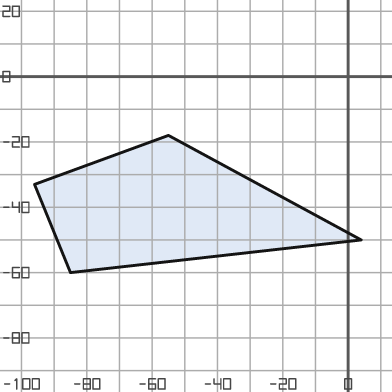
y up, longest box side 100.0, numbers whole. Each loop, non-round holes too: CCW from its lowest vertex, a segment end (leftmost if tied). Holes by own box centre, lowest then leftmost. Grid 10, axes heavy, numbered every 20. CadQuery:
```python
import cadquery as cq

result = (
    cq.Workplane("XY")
    .moveTo(-85.0, -60.0)
    .lineTo(4.0, -50.0)
    .lineTo(-55.0, -18.0)
    .lineTo(-96.0, -33.0)
    .close()
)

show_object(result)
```